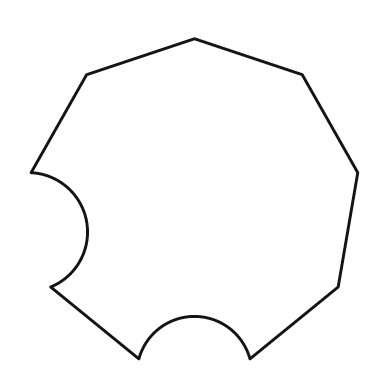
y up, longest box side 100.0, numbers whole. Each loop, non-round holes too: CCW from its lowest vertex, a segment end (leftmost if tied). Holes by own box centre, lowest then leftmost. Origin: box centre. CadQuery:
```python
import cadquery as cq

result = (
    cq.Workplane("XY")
    .moveTo(-17.0, -49.0)
    .threePointArc((0.0, -36.0), (17.0, -49.0))
    .lineTo(44.0, -27.0)
    .lineTo(50.0, 8.0)
    .lineTo(33.0, 38.0)
    .lineTo(0.0, 49.0)
    .lineTo(-33.0, 38.0)
    .lineTo(-50.0, 8.0)
    .threePointArc((-33.0, -7.0), (-44.0, -27.0))
    .close()
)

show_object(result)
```